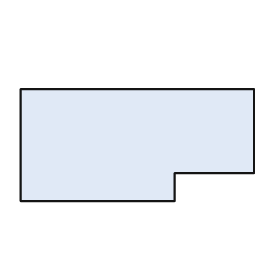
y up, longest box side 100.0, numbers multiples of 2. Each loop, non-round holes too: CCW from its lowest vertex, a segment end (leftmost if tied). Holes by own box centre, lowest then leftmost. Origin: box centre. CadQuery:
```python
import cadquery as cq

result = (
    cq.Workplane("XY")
    .moveTo(-50.0, -24.0)
    .lineTo(16.0, -24.0)
    .lineTo(16.0, -12.0)
    .lineTo(50.0, -12.0)
    .lineTo(50.0, 24.0)
    .lineTo(-50.0, 24.0)
    .close()
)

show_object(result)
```